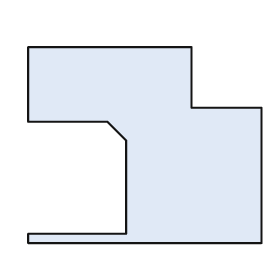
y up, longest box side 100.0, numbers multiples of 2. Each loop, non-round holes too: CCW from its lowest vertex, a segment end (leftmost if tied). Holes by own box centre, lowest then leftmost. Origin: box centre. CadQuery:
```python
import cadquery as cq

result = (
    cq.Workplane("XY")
    .moveTo(-50.0, -42.0)
    .lineTo(50.0, -42.0)
    .lineTo(50.0, 16.0)
    .lineTo(20.0, 16.0)
    .lineTo(20.0, 42.0)
    .lineTo(-50.0, 42.0)
    .lineTo(-50.0, 10.0)
    .lineTo(-16.0, 10.0)
    .lineTo(-8.0, 2.0)
    .lineTo(-8.0, -38.0)
    .lineTo(-50.0, -38.0)
    .close()
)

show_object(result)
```